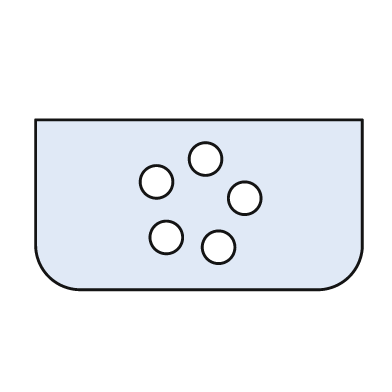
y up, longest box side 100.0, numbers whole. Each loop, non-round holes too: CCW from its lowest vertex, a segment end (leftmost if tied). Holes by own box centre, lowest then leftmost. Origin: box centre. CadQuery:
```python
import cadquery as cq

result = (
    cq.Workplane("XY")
    .moveTo(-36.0, -26.0)
    .lineTo(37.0, -26.0)
    .threePointArc((46.0, -22.0), (50.0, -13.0))
    .lineTo(50.0, 26.0)
    .lineTo(-50.0, 26.0)
    .lineTo(-50.0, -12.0)
    .threePointArc((-46.0, -22.0), (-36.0, -26.0))
    .close()
    .moveTo(6.0, -13.0)
    .circle(5.0)
    .moveTo(-10.0, -10.0)
    .circle(5.0)
    .moveTo(14.0, 2.0)
    .circle(5.0)
    .moveTo(-13.0, 7.0)
    .circle(5.0)
    .moveTo(2.0, 14.0)
    .circle(5.0)
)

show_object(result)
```